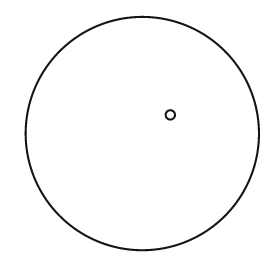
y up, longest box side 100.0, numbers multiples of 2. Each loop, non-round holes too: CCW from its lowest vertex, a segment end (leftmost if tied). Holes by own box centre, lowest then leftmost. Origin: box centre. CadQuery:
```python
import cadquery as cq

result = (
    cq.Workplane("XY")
    .moveTo(0.0, 0.0)
    .circle(50.0)
    .moveTo(12.0, 8.0)
    .circle(2.0)
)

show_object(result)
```